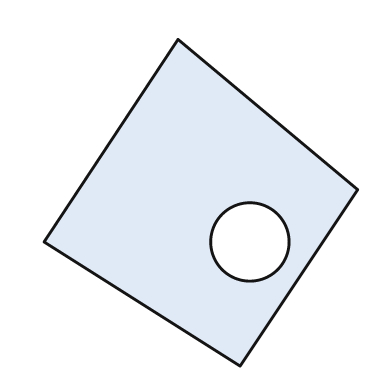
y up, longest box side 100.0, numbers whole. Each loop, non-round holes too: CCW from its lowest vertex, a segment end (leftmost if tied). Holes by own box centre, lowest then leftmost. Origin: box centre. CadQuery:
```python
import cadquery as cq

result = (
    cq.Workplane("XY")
    .moveTo(12.0, -50.0)
    .lineTo(48.0, 4.0)
    .lineTo(-7.0, 50.0)
    .lineTo(-48.0, -12.0)
    .close()
    .moveTo(15.0, -12.0)
    .circle(12.0)
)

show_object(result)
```